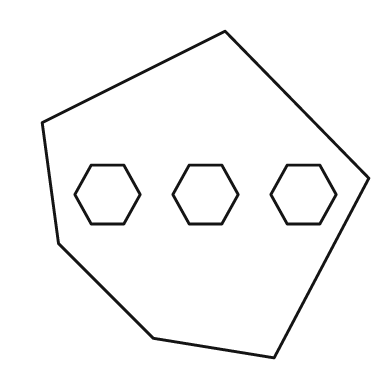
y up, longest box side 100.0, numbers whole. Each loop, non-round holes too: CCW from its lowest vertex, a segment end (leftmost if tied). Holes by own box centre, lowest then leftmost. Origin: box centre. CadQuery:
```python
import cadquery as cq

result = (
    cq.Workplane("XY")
    .moveTo(21.0, -50.0)
    .lineTo(50.0, 5.0)
    .lineTo(6.0, 50.0)
    .lineTo(-50.0, 22.0)
    .lineTo(-45.0, -15.0)
    .lineTo(-16.0, -44.0)
    .close()
    .moveTo(-35.0, -9.0)
    .lineTo(-25.0, -9.0)
    .lineTo(-20.0, 0.0)
    .lineTo(-25.0, 9.0)
    .lineTo(-35.0, 9.0)
    .lineTo(-40.0, 0.0)
    .close()
    .moveTo(-5.0, -9.0)
    .lineTo(5.0, -9.0)
    .lineTo(10.0, 0.0)
    .lineTo(5.0, 9.0)
    .lineTo(-5.0, 9.0)
    .lineTo(-10.0, 0.0)
    .close()
    .moveTo(25.0, -9.0)
    .lineTo(35.0, -9.0)
    .lineTo(40.0, 0.0)
    .lineTo(35.0, 9.0)
    .lineTo(25.0, 9.0)
    .lineTo(20.0, 0.0)
    .close()
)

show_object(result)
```